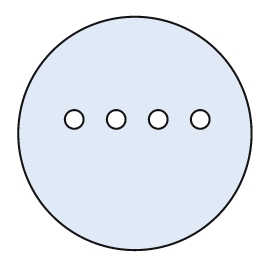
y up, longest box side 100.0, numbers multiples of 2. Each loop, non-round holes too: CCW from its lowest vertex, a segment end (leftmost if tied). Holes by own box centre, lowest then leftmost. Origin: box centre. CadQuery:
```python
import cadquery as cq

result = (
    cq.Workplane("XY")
    .moveTo(0.0, 0.0)
    .circle(50.0)
    .moveTo(-26.0, 6.0)
    .circle(4.0)
    .moveTo(-8.0, 6.0)
    .circle(4.0)
    .moveTo(10.0, 6.0)
    .circle(4.0)
    .moveTo(28.0, 6.0)
    .circle(4.0)
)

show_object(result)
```